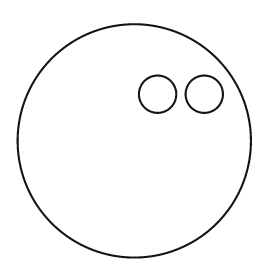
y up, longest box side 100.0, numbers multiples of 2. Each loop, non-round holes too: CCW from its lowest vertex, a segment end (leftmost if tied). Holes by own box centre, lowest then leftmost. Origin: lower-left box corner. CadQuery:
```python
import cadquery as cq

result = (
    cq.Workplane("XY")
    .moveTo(50.0, 50.0)
    .circle(50.0)
    .moveTo(60.0, 70.0)
    .circle(8.0)
    .moveTo(80.0, 70.0)
    .circle(8.0)
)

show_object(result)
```